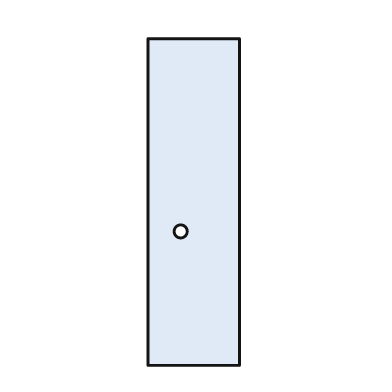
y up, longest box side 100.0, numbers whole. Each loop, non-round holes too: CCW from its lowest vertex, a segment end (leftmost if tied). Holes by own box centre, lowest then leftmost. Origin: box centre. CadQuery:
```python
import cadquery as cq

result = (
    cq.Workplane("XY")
    .moveTo(-14.0, -50.0)
    .lineTo(14.0, -50.0)
    .lineTo(14.0, 50.0)
    .lineTo(-14.0, 50.0)
    .close()
    .moveTo(-4.0, -9.0)
    .circle(2.0)
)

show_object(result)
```